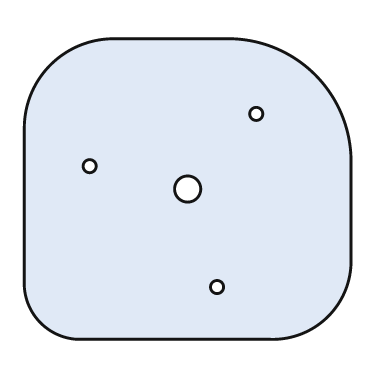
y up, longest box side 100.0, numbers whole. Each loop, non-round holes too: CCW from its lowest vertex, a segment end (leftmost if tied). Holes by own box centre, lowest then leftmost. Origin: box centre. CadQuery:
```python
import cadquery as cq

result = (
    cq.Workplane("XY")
    .moveTo(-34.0, -46.0)
    .lineTo(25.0, -46.0)
    .threePointArc((43.0, -39.0), (50.0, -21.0))
    .lineTo(50.0, 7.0)
    .threePointArc((39.0, 35.0), (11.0, 46.0))
    .lineTo(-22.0, 46.0)
    .threePointArc((-42.0, 38.0), (-50.0, 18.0))
    .lineTo(-50.0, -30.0)
    .threePointArc((-45.0, -41.0), (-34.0, -46.0))
    .close()
    .moveTo(9.0, -30.0)
    .circle(2.0)
    .moveTo(0.0, 0.0)
    .circle(4.0)
    .moveTo(-30.0, 7.0)
    .circle(2.0)
    .moveTo(21.0, 23.0)
    .circle(2.0)
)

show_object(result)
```